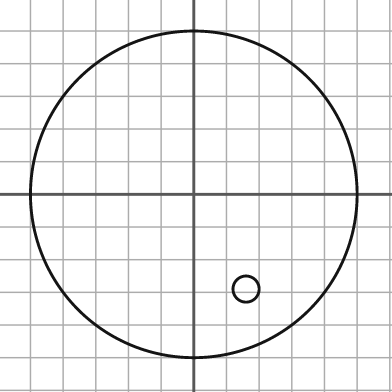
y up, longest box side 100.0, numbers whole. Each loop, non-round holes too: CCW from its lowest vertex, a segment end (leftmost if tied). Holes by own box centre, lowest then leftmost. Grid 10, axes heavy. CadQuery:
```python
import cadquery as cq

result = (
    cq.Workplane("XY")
    .moveTo(0.0, 0.0)
    .circle(50.0)
    .moveTo(16.0, -29.0)
    .circle(4.0)
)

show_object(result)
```